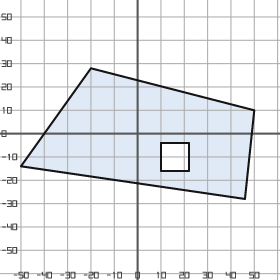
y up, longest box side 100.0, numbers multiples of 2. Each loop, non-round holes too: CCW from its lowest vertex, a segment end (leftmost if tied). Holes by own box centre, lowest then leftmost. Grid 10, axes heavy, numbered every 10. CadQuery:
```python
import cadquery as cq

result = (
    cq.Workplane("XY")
    .moveTo(46.0, -28.0)
    .lineTo(50.0, 10.0)
    .lineTo(-20.0, 28.0)
    .lineTo(-50.0, -14.0)
    .close()
    .moveTo(10.0, -16.0)
    .lineTo(22.0, -16.0)
    .lineTo(22.0, -4.0)
    .lineTo(10.0, -4.0)
    .close()
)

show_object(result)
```